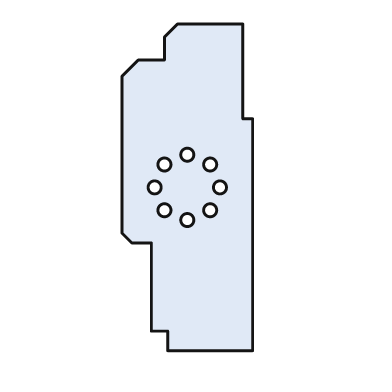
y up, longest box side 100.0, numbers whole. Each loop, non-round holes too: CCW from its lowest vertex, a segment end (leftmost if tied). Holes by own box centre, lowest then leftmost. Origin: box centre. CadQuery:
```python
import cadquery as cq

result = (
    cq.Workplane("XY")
    .moveTo(-6.0, -50.0)
    .lineTo(20.0, -50.0)
    .lineTo(20.0, 21.0)
    .lineTo(17.0, 21.0)
    .lineTo(17.0, 50.0)
    .lineTo(-3.0, 50.0)
    .lineTo(-7.0, 46.0)
    .lineTo(-7.0, 39.0)
    .lineTo(-15.0, 39.0)
    .lineTo(-20.0, 34.0)
    .lineTo(-20.0, -14.0)
    .lineTo(-17.0, -17.0)
    .lineTo(-11.0, -17.0)
    .lineTo(-11.0, -44.0)
    .lineTo(-6.0, -44.0)
    .close()
    .moveTo(0.0, -10.0)
    .circle(2.0)
    .moveTo(-7.0, -7.0)
    .circle(2.0)
    .moveTo(7.0, -7.0)
    .circle(2.0)
    .moveTo(-10.0, 0.0)
    .circle(2.0)
    .moveTo(10.0, 0.0)
    .circle(2.0)
    .moveTo(-7.0, 7.0)
    .circle(2.0)
    .moveTo(7.0, 7.0)
    .circle(2.0)
    .moveTo(0.0, 10.0)
    .circle(2.0)
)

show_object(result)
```